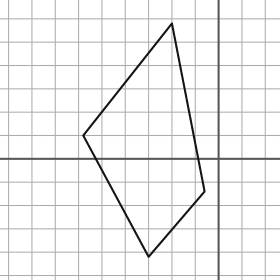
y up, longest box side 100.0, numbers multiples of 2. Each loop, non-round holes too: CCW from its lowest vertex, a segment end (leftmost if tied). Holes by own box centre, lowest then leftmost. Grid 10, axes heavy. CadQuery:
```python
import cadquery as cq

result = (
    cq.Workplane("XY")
    .moveTo(-30.0, -42.0)
    .lineTo(-6.0, -14.0)
    .lineTo(-20.0, 58.0)
    .lineTo(-58.0, 10.0)
    .close()
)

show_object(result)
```